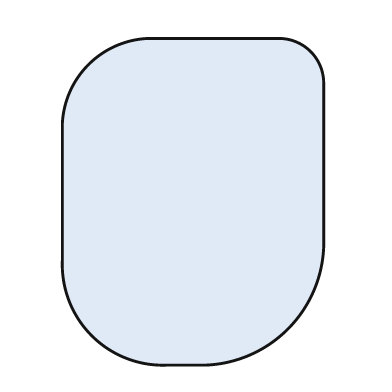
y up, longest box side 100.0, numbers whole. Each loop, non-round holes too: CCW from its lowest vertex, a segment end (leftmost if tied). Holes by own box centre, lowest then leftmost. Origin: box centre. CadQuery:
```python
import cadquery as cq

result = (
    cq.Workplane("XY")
    .moveTo(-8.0, -50.0)
    .lineTo(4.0, -50.0)
    .threePointArc((29.0, -39.0), (40.0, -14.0))
    .lineTo(40.0, 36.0)
    .threePointArc((36.0, 46.0), (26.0, 50.0))
    .lineTo(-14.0, 50.0)
    .threePointArc((-32.0, 42.0), (-40.0, 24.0))
    .lineTo(-40.0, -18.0)
    .threePointArc((-31.0, -41.0), (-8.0, -50.0))
    .close()
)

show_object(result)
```